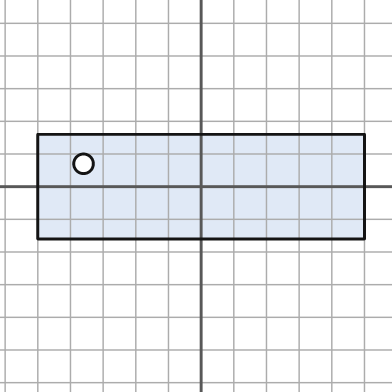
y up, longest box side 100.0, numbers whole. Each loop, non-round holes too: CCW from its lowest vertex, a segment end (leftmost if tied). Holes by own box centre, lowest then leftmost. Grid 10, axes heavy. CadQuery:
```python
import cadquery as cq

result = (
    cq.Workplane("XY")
    .moveTo(-50.0, -16.0)
    .lineTo(50.0, -16.0)
    .lineTo(50.0, 16.0)
    .lineTo(-50.0, 16.0)
    .close()
    .moveTo(-36.0, 7.0)
    .circle(3.0)
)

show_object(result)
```